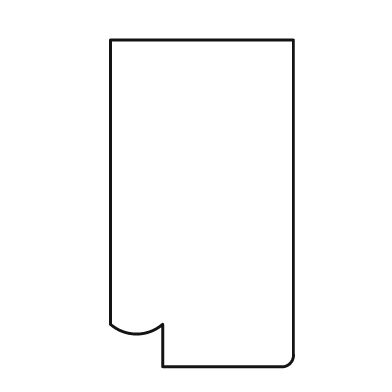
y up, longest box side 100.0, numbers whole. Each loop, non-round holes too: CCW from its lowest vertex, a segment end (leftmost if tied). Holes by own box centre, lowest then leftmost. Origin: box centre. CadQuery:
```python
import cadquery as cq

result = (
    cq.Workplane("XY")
    .moveTo(-12.0, -50.0)
    .lineTo(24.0, -50.0)
    .threePointArc((27.0, -49.0), (28.0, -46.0))
    .lineTo(28.0, 50.0)
    .lineTo(-28.0, 50.0)
    .lineTo(-28.0, -37.0)
    .threePointArc((-20.0, -40.0), (-12.0, -37.0))
    .close()
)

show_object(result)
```